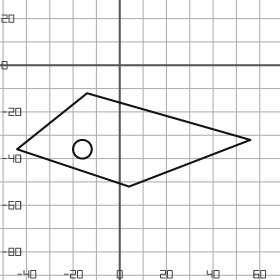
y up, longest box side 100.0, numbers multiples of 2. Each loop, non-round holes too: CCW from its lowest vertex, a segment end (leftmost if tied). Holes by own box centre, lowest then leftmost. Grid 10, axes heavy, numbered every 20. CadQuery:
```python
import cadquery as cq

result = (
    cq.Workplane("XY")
    .moveTo(4.0, -52.0)
    .lineTo(56.0, -32.0)
    .lineTo(-14.0, -12.0)
    .lineTo(-44.0, -36.0)
    .close()
    .moveTo(-16.0, -36.0)
    .circle(4.0)
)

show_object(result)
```